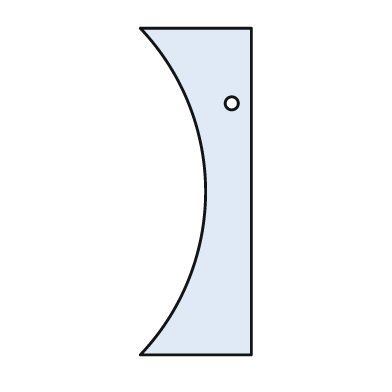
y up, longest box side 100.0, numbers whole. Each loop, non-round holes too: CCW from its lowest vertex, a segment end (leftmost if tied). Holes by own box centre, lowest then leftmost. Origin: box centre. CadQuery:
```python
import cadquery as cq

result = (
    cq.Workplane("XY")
    .moveTo(-17.0, -50.0)
    .lineTo(17.0, -50.0)
    .lineTo(17.0, 50.0)
    .lineTo(-17.0, 50.0)
    .threePointArc((3.0, 0.0), (-17.0, -50.0))
    .close()
    .moveTo(11.0, 27.0)
    .circle(2.0)
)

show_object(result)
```